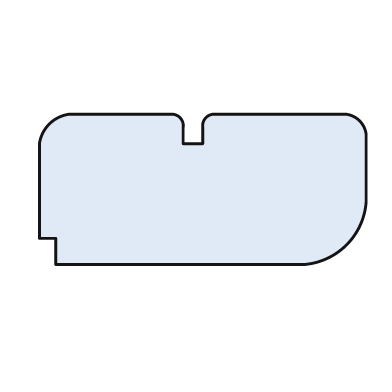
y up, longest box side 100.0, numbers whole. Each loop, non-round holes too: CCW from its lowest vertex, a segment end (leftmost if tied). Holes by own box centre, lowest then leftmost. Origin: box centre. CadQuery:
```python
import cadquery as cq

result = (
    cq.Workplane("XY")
    .moveTo(-45.0, -23.0)
    .lineTo(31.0, -23.0)
    .threePointArc((44.0, -17.0), (50.0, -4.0))
    .lineTo(50.0, 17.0)
    .threePointArc((48.0, 21.0), (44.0, 23.0))
    .lineTo(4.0, 23.0)
    .threePointArc((1.0, 22.0), (0.0, 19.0))
    .lineTo(0.0, 14.0)
    .lineTo(-6.0, 14.0)
    .lineTo(-6.0, 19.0)
    .threePointArc((-7.0, 22.0), (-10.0, 23.0))
    .lineTo(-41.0, 23.0)
    .threePointArc((-47.0, 20.0), (-50.0, 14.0))
    .lineTo(-50.0, -15.0)
    .lineTo(-45.0, -15.0)
    .close()
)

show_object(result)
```